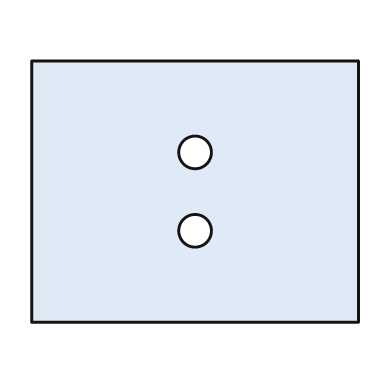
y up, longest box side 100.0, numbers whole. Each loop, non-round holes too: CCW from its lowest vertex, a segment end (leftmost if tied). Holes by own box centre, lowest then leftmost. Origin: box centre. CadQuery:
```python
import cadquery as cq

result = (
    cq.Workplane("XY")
    .moveTo(-50.0, -40.0)
    .lineTo(50.0, -40.0)
    .lineTo(50.0, 40.0)
    .lineTo(-50.0, 40.0)
    .close()
    .moveTo(0.0, -12.0)
    .circle(5.0)
    .moveTo(0.0, 12.0)
    .circle(5.0)
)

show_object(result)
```